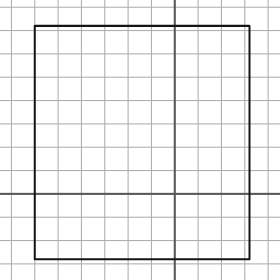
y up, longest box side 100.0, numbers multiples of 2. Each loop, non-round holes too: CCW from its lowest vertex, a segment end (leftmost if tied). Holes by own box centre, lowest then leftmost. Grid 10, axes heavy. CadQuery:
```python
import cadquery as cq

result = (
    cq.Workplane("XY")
    .moveTo(-60.0, -28.0)
    .lineTo(32.0, -28.0)
    .lineTo(32.0, 72.0)
    .lineTo(-60.0, 72.0)
    .close()
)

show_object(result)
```